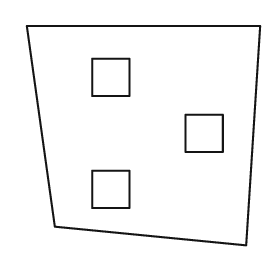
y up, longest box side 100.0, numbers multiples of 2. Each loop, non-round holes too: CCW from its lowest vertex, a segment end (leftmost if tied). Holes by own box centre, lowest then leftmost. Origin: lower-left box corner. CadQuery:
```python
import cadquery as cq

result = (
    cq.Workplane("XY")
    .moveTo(94.0, 0.0)
    .lineTo(100.0, 94.0)
    .lineTo(0.0, 94.0)
    .lineTo(12.0, 8.0)
    .close()
    .moveTo(28.0, 16.0)
    .lineTo(44.0, 16.0)
    .lineTo(44.0, 32.0)
    .lineTo(28.0, 32.0)
    .close()
    .moveTo(68.0, 40.0)
    .lineTo(84.0, 40.0)
    .lineTo(84.0, 56.0)
    .lineTo(68.0, 56.0)
    .close()
    .moveTo(28.0, 64.0)
    .lineTo(44.0, 64.0)
    .lineTo(44.0, 80.0)
    .lineTo(28.0, 80.0)
    .close()
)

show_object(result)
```